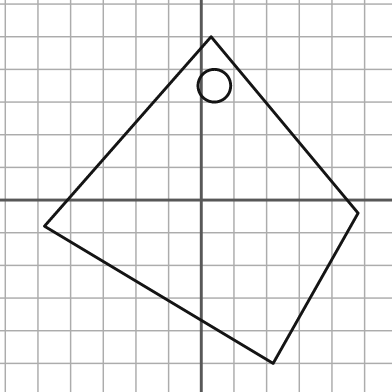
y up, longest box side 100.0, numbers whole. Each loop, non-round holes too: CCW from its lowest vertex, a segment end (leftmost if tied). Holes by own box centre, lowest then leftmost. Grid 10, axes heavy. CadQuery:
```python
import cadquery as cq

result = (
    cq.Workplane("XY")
    .moveTo(22.0, -50.0)
    .lineTo(48.0, -4.0)
    .lineTo(3.0, 50.0)
    .lineTo(-48.0, -8.0)
    .close()
    .moveTo(4.0, 35.0)
    .circle(5.0)
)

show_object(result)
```